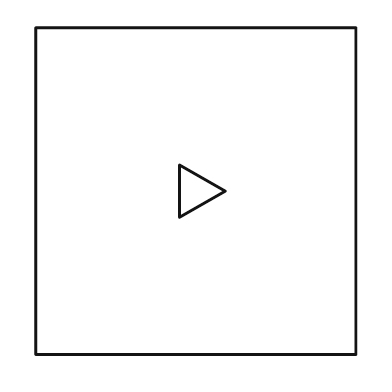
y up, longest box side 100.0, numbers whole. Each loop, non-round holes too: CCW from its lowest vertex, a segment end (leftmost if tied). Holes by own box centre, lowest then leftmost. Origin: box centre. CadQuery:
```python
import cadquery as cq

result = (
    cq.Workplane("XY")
    .moveTo(-49.0, -50.0)
    .lineTo(49.0, -50.0)
    .lineTo(49.0, 50.0)
    .lineTo(-49.0, 50.0)
    .close()
    .moveTo(-5.0, -8.0)
    .lineTo(9.0, 0.0)
    .lineTo(-5.0, 8.0)
    .close()
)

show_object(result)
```